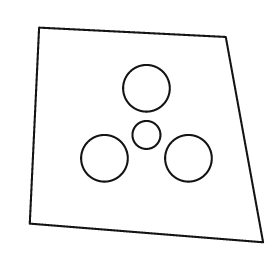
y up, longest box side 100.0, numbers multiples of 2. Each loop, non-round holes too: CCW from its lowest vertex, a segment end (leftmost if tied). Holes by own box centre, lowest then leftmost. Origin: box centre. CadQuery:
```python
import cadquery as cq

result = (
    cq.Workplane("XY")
    .moveTo(50.0, -46.0)
    .lineTo(34.0, 42.0)
    .lineTo(-46.0, 46.0)
    .lineTo(-50.0, -38.0)
    .close()
    .moveTo(-18.0, -10.0)
    .circle(10.0)
    .moveTo(18.0, -10.0)
    .circle(10.0)
    .moveTo(0.0, 0.0)
    .circle(6.0)
    .moveTo(0.0, 20.0)
    .circle(10.0)
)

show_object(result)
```